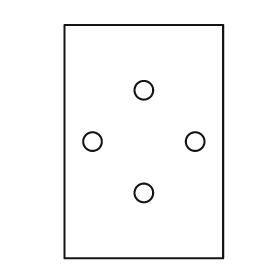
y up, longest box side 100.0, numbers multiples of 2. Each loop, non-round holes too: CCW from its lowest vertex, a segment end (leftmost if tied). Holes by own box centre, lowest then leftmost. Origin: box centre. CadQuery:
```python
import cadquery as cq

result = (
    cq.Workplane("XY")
    .moveTo(-34.0, -50.0)
    .lineTo(34.0, -50.0)
    .lineTo(34.0, 50.0)
    .lineTo(-34.0, 50.0)
    .close()
    .moveTo(0.0, -22.0)
    .circle(4.0)
    .moveTo(-22.0, 0.0)
    .circle(4.0)
    .moveTo(22.0, 0.0)
    .circle(4.0)
    .moveTo(0.0, 22.0)
    .circle(4.0)
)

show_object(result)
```